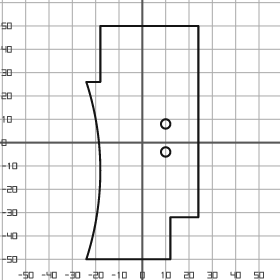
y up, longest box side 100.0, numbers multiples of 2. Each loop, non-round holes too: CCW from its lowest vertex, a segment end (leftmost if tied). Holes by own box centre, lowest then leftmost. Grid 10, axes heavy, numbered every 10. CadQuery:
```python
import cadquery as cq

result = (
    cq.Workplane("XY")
    .moveTo(-24.0, -50.0)
    .lineTo(12.0, -50.0)
    .lineTo(12.0, -32.0)
    .lineTo(24.0, -32.0)
    .lineTo(24.0, 50.0)
    .lineTo(-18.0, 50.0)
    .lineTo(-18.0, 26.0)
    .lineTo(-24.0, 26.0)
    .threePointArc((-18.0, -12.0), (-24.0, -50.0))
    .close()
    .moveTo(10.0, -4.0)
    .circle(2.0)
    .moveTo(10.0, 8.0)
    .circle(2.0)
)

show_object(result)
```